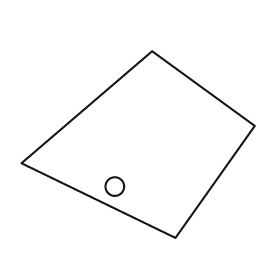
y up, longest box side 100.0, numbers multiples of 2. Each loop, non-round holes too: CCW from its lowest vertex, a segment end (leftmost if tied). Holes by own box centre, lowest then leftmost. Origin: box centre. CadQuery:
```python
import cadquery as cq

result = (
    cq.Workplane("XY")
    .moveTo(16.0, -40.0)
    .lineTo(50.0, 8.0)
    .lineTo(6.0, 40.0)
    .lineTo(-50.0, -8.0)
    .close()
    .moveTo(-10.0, -18.0)
    .circle(4.0)
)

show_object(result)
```